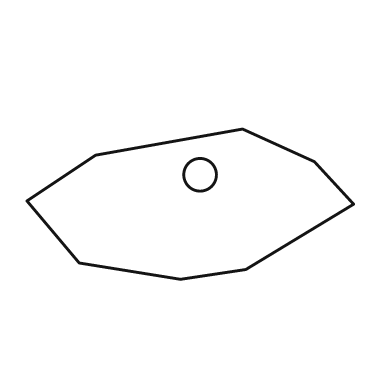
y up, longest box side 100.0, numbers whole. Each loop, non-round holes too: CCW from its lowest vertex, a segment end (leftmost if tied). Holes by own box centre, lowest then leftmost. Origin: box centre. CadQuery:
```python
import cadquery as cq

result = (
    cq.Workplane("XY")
    .moveTo(-3.0, -23.0)
    .lineTo(17.0, -20.0)
    .lineTo(50.0, 0.0)
    .lineTo(38.0, 13.0)
    .lineTo(16.0, 23.0)
    .lineTo(-29.0, 15.0)
    .lineTo(-50.0, 1.0)
    .lineTo(-34.0, -18.0)
    .close()
    .moveTo(3.0, 9.0)
    .circle(5.0)
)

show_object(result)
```